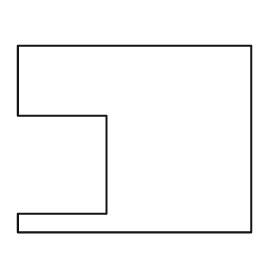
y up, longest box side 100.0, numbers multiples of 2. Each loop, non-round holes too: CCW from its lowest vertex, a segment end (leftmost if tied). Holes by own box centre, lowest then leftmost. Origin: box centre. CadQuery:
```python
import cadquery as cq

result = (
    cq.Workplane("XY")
    .moveTo(-50.0, -40.0)
    .lineTo(50.0, -40.0)
    .lineTo(50.0, 40.0)
    .lineTo(-50.0, 40.0)
    .lineTo(-50.0, 10.0)
    .lineTo(-12.0, 10.0)
    .lineTo(-12.0, -32.0)
    .lineTo(-50.0, -32.0)
    .close()
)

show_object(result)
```